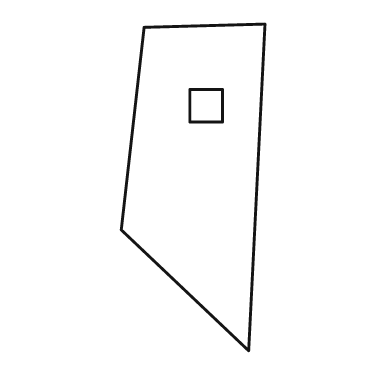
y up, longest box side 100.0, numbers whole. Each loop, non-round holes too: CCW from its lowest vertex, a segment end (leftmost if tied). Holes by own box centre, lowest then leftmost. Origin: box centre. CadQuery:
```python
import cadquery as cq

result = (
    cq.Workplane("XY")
    .moveTo(17.0, -50.0)
    .lineTo(22.0, 50.0)
    .lineTo(-15.0, 49.0)
    .lineTo(-22.0, -13.0)
    .close()
    .moveTo(-1.0, 20.0)
    .lineTo(9.0, 20.0)
    .lineTo(9.0, 30.0)
    .lineTo(-1.0, 30.0)
    .close()
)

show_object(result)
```